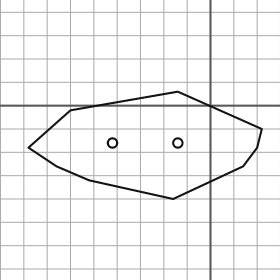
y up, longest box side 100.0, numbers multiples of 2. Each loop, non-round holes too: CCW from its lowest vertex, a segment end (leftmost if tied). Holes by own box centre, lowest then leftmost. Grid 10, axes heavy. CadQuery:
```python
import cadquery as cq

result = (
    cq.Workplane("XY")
    .moveTo(-16.0, -40.0)
    .lineTo(14.0, -26.0)
    .lineTo(20.0, -18.0)
    .lineTo(22.0, -10.0)
    .lineTo(-14.0, 6.0)
    .lineTo(-60.0, -2.0)
    .lineTo(-78.0, -18.0)
    .lineTo(-66.0, -26.0)
    .lineTo(-52.0, -32.0)
    .close()
    .moveTo(-42.0, -16.0)
    .circle(2.0)
    .moveTo(-14.0, -16.0)
    .circle(2.0)
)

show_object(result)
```